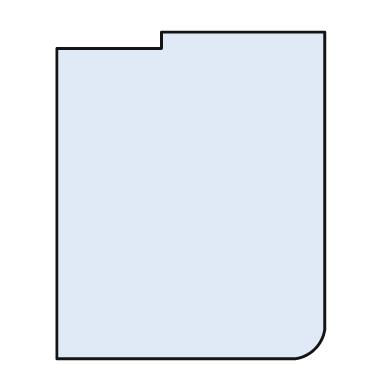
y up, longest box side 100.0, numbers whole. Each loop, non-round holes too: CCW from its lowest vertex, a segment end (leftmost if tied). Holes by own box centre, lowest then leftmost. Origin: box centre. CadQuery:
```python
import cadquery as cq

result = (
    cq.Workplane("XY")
    .moveTo(-41.0, -50.0)
    .lineTo(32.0, -50.0)
    .threePointArc((38.0, -47.0), (41.0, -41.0))
    .lineTo(41.0, 50.0)
    .lineTo(-9.0, 50.0)
    .lineTo(-9.0, 45.0)
    .lineTo(-41.0, 45.0)
    .close()
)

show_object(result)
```